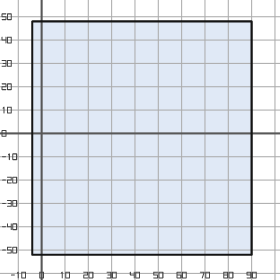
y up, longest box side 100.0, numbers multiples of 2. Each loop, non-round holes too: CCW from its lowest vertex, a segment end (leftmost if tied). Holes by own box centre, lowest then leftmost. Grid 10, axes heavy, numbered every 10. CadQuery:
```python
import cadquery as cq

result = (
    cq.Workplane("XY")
    .moveTo(-4.0, -52.0)
    .lineTo(90.0, -52.0)
    .lineTo(90.0, 48.0)
    .lineTo(-4.0, 48.0)
    .close()
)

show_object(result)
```